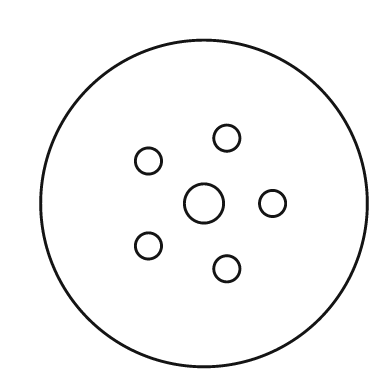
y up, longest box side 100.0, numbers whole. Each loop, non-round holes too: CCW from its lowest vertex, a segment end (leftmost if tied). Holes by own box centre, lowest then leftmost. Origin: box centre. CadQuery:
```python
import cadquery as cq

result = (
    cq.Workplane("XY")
    .moveTo(0.0, 0.0)
    .circle(50.0)
    .moveTo(7.0, -20.0)
    .circle(4.0)
    .moveTo(-17.0, -13.0)
    .circle(4.0)
    .moveTo(0.0, 0.0)
    .circle(6.0)
    .moveTo(21.0, 0.0)
    .circle(4.0)
    .moveTo(-17.0, 13.0)
    .circle(4.0)
    .moveTo(7.0, 20.0)
    .circle(4.0)
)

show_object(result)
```